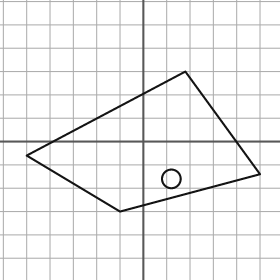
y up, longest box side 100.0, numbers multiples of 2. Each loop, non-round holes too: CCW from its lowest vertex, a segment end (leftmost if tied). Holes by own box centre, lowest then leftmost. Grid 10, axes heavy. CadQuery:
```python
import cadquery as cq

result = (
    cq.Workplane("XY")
    .moveTo(-10.0, -30.0)
    .lineTo(50.0, -14.0)
    .lineTo(18.0, 30.0)
    .lineTo(-50.0, -6.0)
    .close()
    .moveTo(12.0, -16.0)
    .circle(4.0)
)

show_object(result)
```